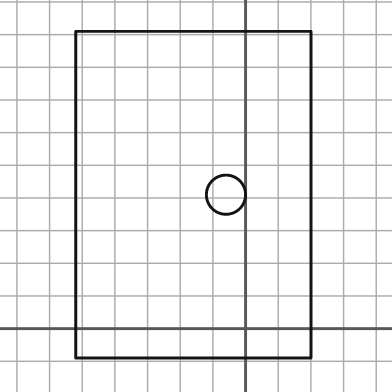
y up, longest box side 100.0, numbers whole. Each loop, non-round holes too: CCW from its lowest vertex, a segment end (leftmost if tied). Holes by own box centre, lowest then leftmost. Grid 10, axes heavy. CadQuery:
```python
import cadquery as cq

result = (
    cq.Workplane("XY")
    .moveTo(-52.0, -9.0)
    .lineTo(20.0, -9.0)
    .lineTo(20.0, 91.0)
    .lineTo(-52.0, 91.0)
    .close()
    .moveTo(-6.0, 41.0)
    .circle(6.0)
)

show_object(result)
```